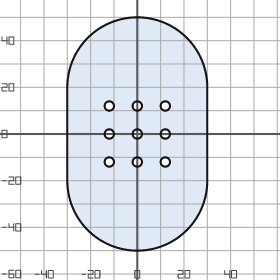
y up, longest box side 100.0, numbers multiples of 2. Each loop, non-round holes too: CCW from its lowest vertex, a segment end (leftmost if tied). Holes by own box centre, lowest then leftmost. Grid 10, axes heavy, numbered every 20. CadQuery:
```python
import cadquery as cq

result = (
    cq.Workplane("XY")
    .moveTo(-30.0, -20.0)
    .threePointArc((0.0, -50.0), (30.0, -20.0))
    .lineTo(30.0, 20.0)
    .threePointArc((0.0, 50.0), (-30.0, 20.0))
    .close()
    .moveTo(-12.0, -12.0)
    .circle(2.0)
    .moveTo(0.0, -12.0)
    .circle(2.0)
    .moveTo(12.0, -12.0)
    .circle(2.0)
    .moveTo(-12.0, 0.0)
    .circle(2.0)
    .moveTo(0.0, 0.0)
    .circle(2.0)
    .moveTo(12.0, 0.0)
    .circle(2.0)
    .moveTo(-12.0, 12.0)
    .circle(2.0)
    .moveTo(0.0, 12.0)
    .circle(2.0)
    .moveTo(12.0, 12.0)
    .circle(2.0)
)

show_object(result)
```